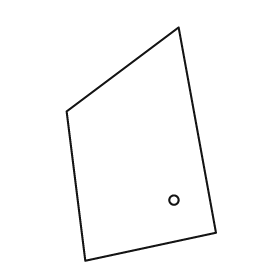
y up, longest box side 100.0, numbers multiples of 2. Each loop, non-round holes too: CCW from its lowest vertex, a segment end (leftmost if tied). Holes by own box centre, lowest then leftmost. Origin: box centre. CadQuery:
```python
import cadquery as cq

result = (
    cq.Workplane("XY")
    .moveTo(-24.0, -50.0)
    .lineTo(32.0, -38.0)
    .lineTo(16.0, 50.0)
    .lineTo(-32.0, 14.0)
    .close()
    .moveTo(14.0, -24.0)
    .circle(2.0)
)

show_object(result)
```